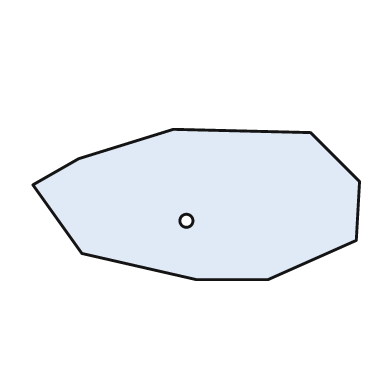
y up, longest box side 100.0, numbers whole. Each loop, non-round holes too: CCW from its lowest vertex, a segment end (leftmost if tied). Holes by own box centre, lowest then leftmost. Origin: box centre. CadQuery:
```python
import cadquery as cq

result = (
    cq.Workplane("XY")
    .moveTo(0.0, -23.0)
    .lineTo(22.0, -23.0)
    .lineTo(49.0, -11.0)
    .lineTo(50.0, 7.0)
    .lineTo(35.0, 22.0)
    .lineTo(-7.0, 23.0)
    .lineTo(-36.0, 14.0)
    .lineTo(-50.0, 6.0)
    .lineTo(-35.0, -15.0)
    .close()
    .moveTo(-3.0, -5.0)
    .circle(2.0)
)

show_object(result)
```